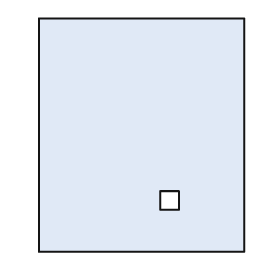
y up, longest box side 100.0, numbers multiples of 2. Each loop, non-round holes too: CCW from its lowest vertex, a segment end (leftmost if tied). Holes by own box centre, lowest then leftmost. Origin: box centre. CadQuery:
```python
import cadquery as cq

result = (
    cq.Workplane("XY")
    .moveTo(-44.0, -50.0)
    .lineTo(44.0, -50.0)
    .lineTo(44.0, 50.0)
    .lineTo(-44.0, 50.0)
    .close()
    .moveTo(8.0, -32.0)
    .lineTo(16.0, -32.0)
    .lineTo(16.0, -24.0)
    .lineTo(8.0, -24.0)
    .close()
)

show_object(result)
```